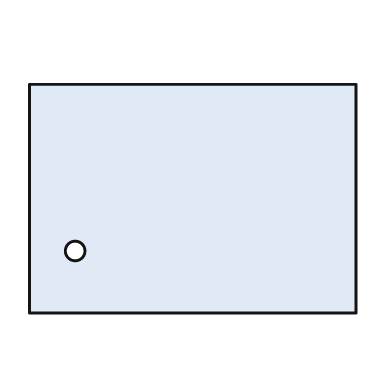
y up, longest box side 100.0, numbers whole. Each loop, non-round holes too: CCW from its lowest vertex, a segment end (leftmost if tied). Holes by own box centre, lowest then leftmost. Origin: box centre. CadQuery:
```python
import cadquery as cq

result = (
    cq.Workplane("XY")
    .moveTo(-50.0, -35.0)
    .lineTo(50.0, -35.0)
    .lineTo(50.0, 35.0)
    .lineTo(-50.0, 35.0)
    .close()
    .moveTo(-36.0, -16.0)
    .circle(3.0)
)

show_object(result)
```